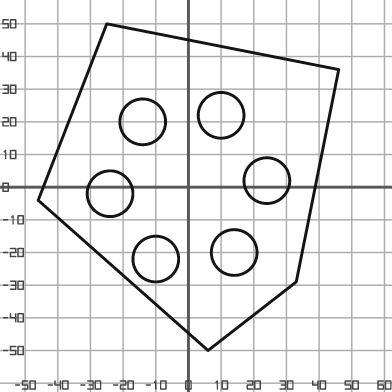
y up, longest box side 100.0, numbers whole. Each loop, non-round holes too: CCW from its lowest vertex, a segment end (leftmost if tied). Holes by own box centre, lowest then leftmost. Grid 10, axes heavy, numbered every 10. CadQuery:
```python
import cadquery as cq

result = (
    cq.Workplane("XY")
    .moveTo(6.0, -50.0)
    .lineTo(33.0, -29.0)
    .lineTo(46.0, 36.0)
    .lineTo(-25.0, 50.0)
    .lineTo(-46.0, -4.0)
    .close()
    .moveTo(-10.0, -22.0)
    .circle(7.0)
    .moveTo(14.0, -20.0)
    .circle(7.0)
    .moveTo(-24.0, -2.0)
    .circle(7.0)
    .moveTo(24.0, 2.0)
    .circle(7.0)
    .moveTo(-14.0, 20.0)
    .circle(7.0)
    .moveTo(10.0, 22.0)
    .circle(7.0)
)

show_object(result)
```